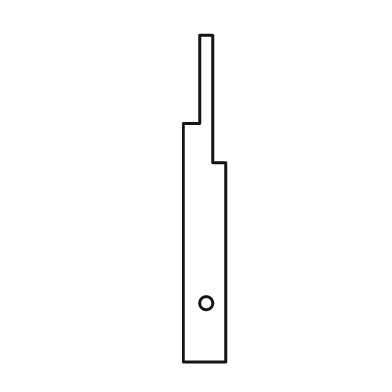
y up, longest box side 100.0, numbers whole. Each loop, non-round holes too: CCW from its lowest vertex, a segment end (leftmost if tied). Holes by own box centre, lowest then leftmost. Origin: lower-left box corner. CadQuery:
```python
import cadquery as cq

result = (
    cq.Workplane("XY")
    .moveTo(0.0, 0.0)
    .lineTo(13.0, 0.0)
    .lineTo(13.0, 61.0)
    .lineTo(9.0, 61.0)
    .lineTo(9.0, 100.0)
    .lineTo(5.0, 100.0)
    .lineTo(5.0, 73.0)
    .lineTo(0.0, 73.0)
    .close()
    .moveTo(7.0, 18.0)
    .circle(2.0)
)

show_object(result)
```